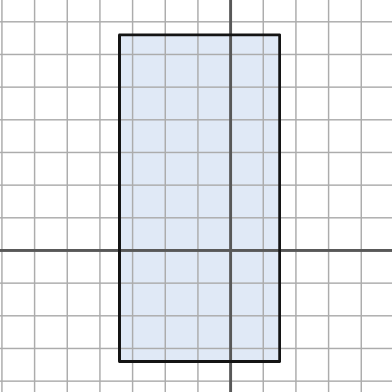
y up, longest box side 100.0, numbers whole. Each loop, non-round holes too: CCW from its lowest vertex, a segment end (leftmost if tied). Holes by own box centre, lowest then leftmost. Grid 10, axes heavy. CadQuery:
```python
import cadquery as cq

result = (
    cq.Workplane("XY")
    .moveTo(-34.0, -34.0)
    .lineTo(15.0, -34.0)
    .lineTo(15.0, 66.0)
    .lineTo(-34.0, 66.0)
    .close()
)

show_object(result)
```